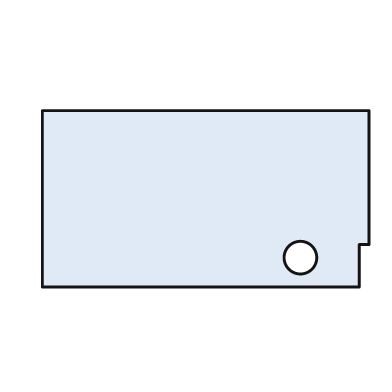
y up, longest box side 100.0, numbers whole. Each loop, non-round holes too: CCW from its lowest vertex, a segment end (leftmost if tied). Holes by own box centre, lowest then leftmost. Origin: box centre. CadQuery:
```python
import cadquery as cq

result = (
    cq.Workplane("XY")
    .moveTo(-50.0, -27.0)
    .lineTo(47.0, -27.0)
    .lineTo(47.0, -14.0)
    .lineTo(50.0, -14.0)
    .lineTo(50.0, 27.0)
    .lineTo(-50.0, 27.0)
    .close()
    .moveTo(29.0, -18.0)
    .circle(5.0)
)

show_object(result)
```